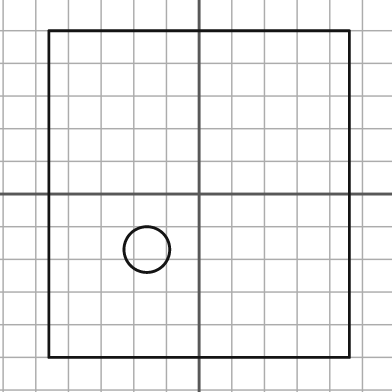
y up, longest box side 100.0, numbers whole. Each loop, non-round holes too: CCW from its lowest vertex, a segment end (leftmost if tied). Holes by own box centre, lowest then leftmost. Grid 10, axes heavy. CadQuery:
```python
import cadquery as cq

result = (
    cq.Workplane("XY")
    .moveTo(-46.0, -50.0)
    .lineTo(46.0, -50.0)
    .lineTo(46.0, 50.0)
    .lineTo(-46.0, 50.0)
    .close()
    .moveTo(-16.0, -17.0)
    .circle(7.0)
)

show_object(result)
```